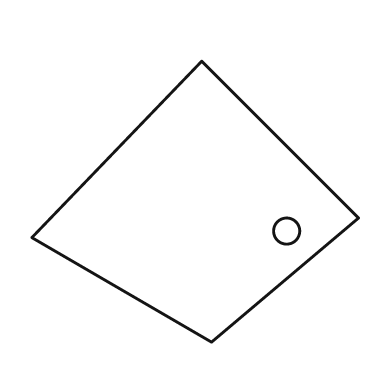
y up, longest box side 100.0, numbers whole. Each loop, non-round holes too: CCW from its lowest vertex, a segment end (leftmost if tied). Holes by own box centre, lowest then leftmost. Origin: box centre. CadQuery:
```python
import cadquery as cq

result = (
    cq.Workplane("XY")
    .moveTo(5.0, -43.0)
    .lineTo(50.0, -5.0)
    .lineTo(2.0, 43.0)
    .lineTo(-50.0, -11.0)
    .close()
    .moveTo(28.0, -9.0)
    .circle(4.0)
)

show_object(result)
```